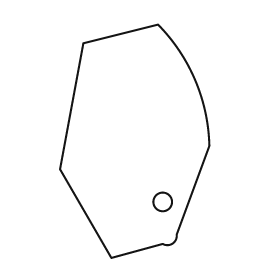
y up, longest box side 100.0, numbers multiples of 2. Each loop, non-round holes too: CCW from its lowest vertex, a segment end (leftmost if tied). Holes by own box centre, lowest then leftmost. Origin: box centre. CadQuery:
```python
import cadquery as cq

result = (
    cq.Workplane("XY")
    .moveTo(-10.0, -50.0)
    .lineTo(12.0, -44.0)
    .threePointArc((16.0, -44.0), (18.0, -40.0))
    .lineTo(32.0, -2.0)
    .threePointArc((26.0, 26.0), (10.0, 50.0))
    .lineTo(-22.0, 42.0)
    .lineTo(-32.0, -12.0)
    .close()
    .moveTo(12.0, -26.0)
    .circle(4.0)
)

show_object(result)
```